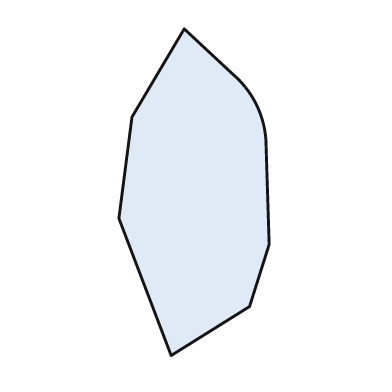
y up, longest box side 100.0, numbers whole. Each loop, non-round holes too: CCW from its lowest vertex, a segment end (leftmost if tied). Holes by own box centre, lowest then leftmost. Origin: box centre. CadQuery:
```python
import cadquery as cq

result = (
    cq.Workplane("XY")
    .moveTo(-7.0, -50.0)
    .lineTo(17.0, -35.0)
    .lineTo(23.0, -16.0)
    .lineTo(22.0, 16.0)
    .threePointArc((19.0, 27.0), (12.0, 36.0))
    .lineTo(-3.0, 50.0)
    .lineTo(-19.0, 23.0)
    .lineTo(-23.0, -8.0)
    .close()
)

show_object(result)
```